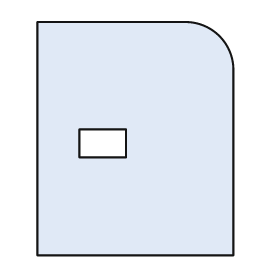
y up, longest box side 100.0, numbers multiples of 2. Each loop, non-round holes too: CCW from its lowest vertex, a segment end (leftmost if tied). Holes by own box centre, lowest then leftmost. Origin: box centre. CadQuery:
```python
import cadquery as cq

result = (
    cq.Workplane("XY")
    .moveTo(-42.0, -50.0)
    .lineTo(42.0, -50.0)
    .lineTo(42.0, 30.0)
    .threePointArc((36.0, 44.0), (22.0, 50.0))
    .lineTo(-42.0, 50.0)
    .close()
    .moveTo(-24.0, -8.0)
    .lineTo(-4.0, -8.0)
    .lineTo(-4.0, 4.0)
    .lineTo(-24.0, 4.0)
    .close()
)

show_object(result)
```